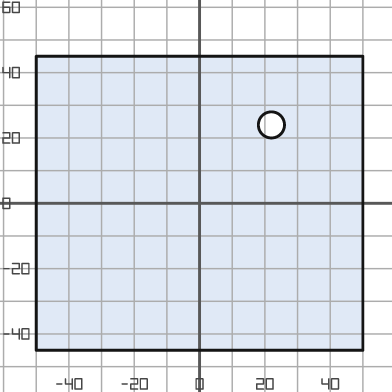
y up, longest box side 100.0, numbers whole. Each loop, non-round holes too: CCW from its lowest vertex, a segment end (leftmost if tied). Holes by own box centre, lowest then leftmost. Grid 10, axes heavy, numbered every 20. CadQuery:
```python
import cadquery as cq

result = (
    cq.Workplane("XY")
    .moveTo(-50.0, -45.0)
    .lineTo(50.0, -45.0)
    .lineTo(50.0, 45.0)
    .lineTo(-50.0, 45.0)
    .close()
    .moveTo(22.0, 24.0)
    .circle(4.0)
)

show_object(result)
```